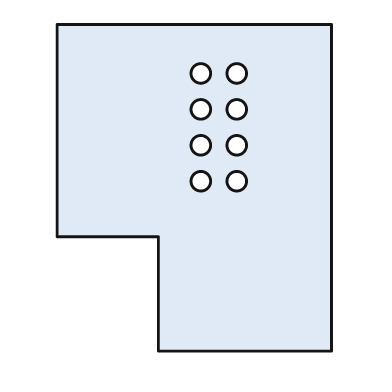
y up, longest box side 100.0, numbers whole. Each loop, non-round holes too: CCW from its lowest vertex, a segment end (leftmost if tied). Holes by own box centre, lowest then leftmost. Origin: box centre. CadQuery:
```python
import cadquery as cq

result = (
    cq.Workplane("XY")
    .moveTo(-11.0, -50.0)
    .lineTo(42.0, -50.0)
    .lineTo(42.0, 50.0)
    .lineTo(-42.0, 50.0)
    .lineTo(-42.0, -15.0)
    .lineTo(-11.0, -15.0)
    .close()
    .moveTo(2.0, 2.0)
    .circle(3.0)
    .moveTo(13.0, 2.0)
    .circle(3.0)
    .moveTo(2.0, 13.0)
    .circle(3.0)
    .moveTo(13.0, 13.0)
    .circle(3.0)
    .moveTo(2.0, 24.0)
    .circle(3.0)
    .moveTo(13.0, 24.0)
    .circle(3.0)
    .moveTo(2.0, 35.0)
    .circle(3.0)
    .moveTo(13.0, 35.0)
    .circle(3.0)
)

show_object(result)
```